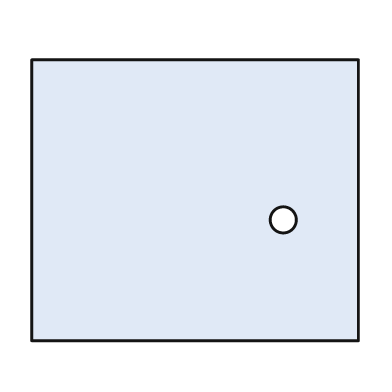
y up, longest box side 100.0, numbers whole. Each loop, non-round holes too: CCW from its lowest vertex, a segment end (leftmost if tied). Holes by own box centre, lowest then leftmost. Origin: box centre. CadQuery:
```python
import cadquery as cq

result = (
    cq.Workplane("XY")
    .moveTo(-50.0, -43.0)
    .lineTo(50.0, -43.0)
    .lineTo(50.0, 43.0)
    .lineTo(-50.0, 43.0)
    .close()
    .moveTo(27.0, -6.0)
    .circle(4.0)
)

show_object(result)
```